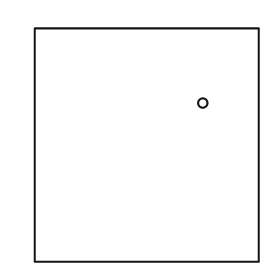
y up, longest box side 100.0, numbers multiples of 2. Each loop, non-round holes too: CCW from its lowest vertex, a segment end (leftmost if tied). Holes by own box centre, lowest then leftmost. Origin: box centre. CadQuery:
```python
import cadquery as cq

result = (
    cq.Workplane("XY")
    .moveTo(-48.0, -50.0)
    .lineTo(48.0, -50.0)
    .lineTo(48.0, 50.0)
    .lineTo(-48.0, 50.0)
    .close()
    .moveTo(24.0, 18.0)
    .circle(2.0)
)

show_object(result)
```